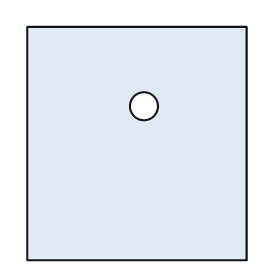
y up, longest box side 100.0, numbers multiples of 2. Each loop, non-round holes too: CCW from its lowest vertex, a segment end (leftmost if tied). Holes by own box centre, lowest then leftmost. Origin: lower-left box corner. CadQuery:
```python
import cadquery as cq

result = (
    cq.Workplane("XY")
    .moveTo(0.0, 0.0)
    .lineTo(94.0, 0.0)
    .lineTo(94.0, 100.0)
    .lineTo(0.0, 100.0)
    .close()
    .moveTo(50.0, 66.0)
    .circle(6.0)
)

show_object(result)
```